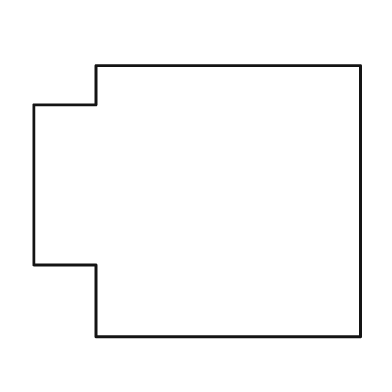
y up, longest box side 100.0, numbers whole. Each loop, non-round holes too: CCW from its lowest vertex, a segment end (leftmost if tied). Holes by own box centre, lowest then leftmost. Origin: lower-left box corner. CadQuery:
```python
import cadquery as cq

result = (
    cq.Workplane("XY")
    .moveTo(19.0, 0.0)
    .lineTo(100.0, 0.0)
    .lineTo(100.0, 83.0)
    .lineTo(19.0, 83.0)
    .lineTo(19.0, 71.0)
    .lineTo(0.0, 71.0)
    .lineTo(0.0, 22.0)
    .lineTo(19.0, 22.0)
    .close()
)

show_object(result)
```